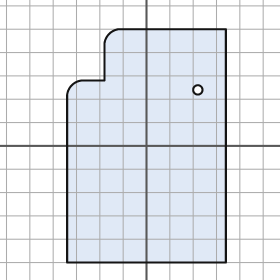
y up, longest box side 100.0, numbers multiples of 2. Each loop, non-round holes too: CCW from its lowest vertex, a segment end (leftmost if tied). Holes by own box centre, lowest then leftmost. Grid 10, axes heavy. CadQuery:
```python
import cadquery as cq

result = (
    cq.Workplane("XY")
    .moveTo(-34.0, -50.0)
    .lineTo(34.0, -50.0)
    .lineTo(34.0, 50.0)
    .lineTo(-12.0, 50.0)
    .threePointArc((-16.0, 48.0), (-18.0, 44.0))
    .lineTo(-18.0, 28.0)
    .lineTo(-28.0, 28.0)
    .threePointArc((-32.0, 26.0), (-34.0, 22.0))
    .close()
    .moveTo(22.0, 24.0)
    .circle(2.0)
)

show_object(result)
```